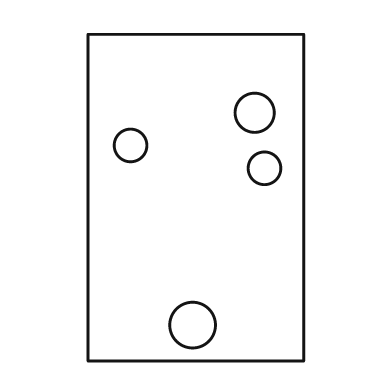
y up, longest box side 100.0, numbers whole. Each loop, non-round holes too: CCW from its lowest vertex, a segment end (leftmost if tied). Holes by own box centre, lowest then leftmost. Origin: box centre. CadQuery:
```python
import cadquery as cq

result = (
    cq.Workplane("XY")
    .moveTo(-33.0, -50.0)
    .lineTo(33.0, -50.0)
    .lineTo(33.0, 50.0)
    .lineTo(-33.0, 50.0)
    .close()
    .moveTo(-1.0, -39.0)
    .circle(7.0)
    .moveTo(21.0, 9.0)
    .circle(5.0)
    .moveTo(-20.0, 16.0)
    .circle(5.0)
    .moveTo(18.0, 26.0)
    .circle(6.0)
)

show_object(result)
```